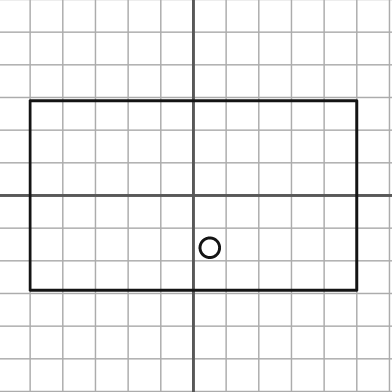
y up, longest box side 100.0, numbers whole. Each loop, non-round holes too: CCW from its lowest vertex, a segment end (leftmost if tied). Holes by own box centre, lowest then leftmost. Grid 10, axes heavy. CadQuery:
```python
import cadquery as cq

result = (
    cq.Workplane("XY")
    .moveTo(-50.0, -29.0)
    .lineTo(50.0, -29.0)
    .lineTo(50.0, 29.0)
    .lineTo(-50.0, 29.0)
    .close()
    .moveTo(5.0, -16.0)
    .circle(3.0)
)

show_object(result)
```